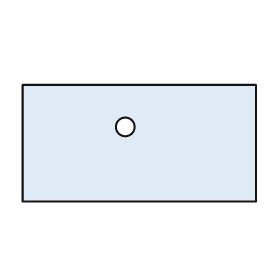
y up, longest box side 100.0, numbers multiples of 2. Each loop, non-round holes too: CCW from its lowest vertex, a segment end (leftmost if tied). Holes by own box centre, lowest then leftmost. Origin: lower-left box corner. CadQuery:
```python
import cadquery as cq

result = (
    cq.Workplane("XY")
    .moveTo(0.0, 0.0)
    .lineTo(100.0, 0.0)
    .lineTo(100.0, 50.0)
    .lineTo(0.0, 50.0)
    .close()
    .moveTo(44.0, 32.0)
    .circle(4.0)
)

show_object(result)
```